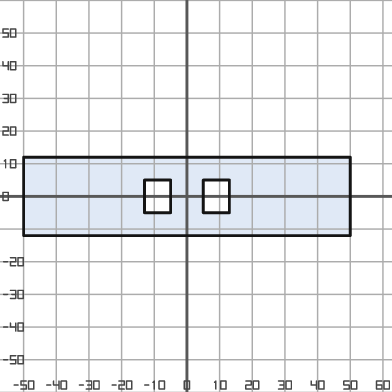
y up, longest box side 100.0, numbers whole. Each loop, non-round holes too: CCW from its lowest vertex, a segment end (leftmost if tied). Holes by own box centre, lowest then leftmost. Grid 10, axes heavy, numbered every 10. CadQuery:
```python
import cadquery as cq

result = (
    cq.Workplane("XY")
    .moveTo(-50.0, -12.0)
    .lineTo(50.0, -12.0)
    .lineTo(50.0, 12.0)
    .lineTo(-50.0, 12.0)
    .close()
    .moveTo(-13.0, -5.0)
    .lineTo(-5.0, -5.0)
    .lineTo(-5.0, 5.0)
    .lineTo(-13.0, 5.0)
    .close()
    .moveTo(5.0, -5.0)
    .lineTo(13.0, -5.0)
    .lineTo(13.0, 5.0)
    .lineTo(5.0, 5.0)
    .close()
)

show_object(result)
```